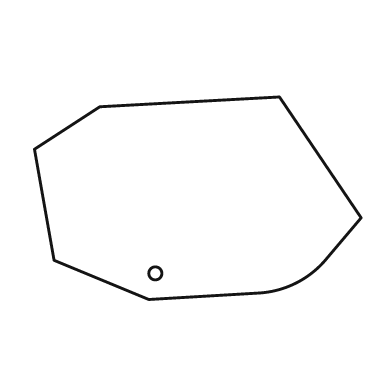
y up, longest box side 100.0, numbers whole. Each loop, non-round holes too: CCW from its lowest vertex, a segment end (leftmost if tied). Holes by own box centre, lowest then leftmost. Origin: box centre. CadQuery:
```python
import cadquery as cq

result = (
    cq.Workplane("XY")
    .moveTo(-15.0, -31.0)
    .lineTo(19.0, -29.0)
    .threePointArc((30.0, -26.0), (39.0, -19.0))
    .lineTo(50.0, -6.0)
    .lineTo(25.0, 31.0)
    .lineTo(-30.0, 28.0)
    .lineTo(-50.0, 15.0)
    .lineTo(-44.0, -19.0)
    .close()
    .moveTo(-13.0, -23.0)
    .circle(2.0)
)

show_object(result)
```